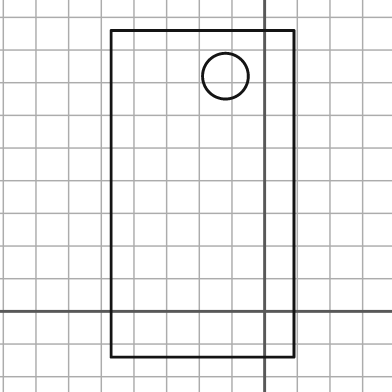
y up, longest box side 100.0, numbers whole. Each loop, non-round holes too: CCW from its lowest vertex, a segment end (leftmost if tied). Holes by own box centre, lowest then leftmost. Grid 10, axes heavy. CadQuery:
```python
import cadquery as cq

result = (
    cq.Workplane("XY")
    .moveTo(-47.0, -14.0)
    .lineTo(9.0, -14.0)
    .lineTo(9.0, 86.0)
    .lineTo(-47.0, 86.0)
    .close()
    .moveTo(-12.0, 72.0)
    .circle(7.0)
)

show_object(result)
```